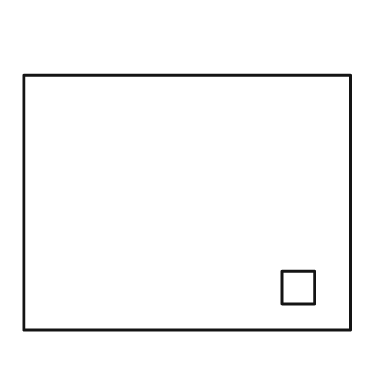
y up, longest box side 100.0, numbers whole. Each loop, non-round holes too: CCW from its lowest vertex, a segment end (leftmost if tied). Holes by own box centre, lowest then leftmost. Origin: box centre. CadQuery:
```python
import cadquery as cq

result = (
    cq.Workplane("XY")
    .moveTo(-50.0, -39.0)
    .lineTo(50.0, -39.0)
    .lineTo(50.0, 39.0)
    .lineTo(-50.0, 39.0)
    .close()
    .moveTo(29.0, -31.0)
    .lineTo(39.0, -31.0)
    .lineTo(39.0, -21.0)
    .lineTo(29.0, -21.0)
    .close()
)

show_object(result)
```